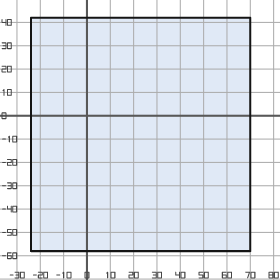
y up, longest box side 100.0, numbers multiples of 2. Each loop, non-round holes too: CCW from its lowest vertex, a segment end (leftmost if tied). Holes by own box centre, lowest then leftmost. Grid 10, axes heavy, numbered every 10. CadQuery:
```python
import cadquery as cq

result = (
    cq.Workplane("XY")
    .moveTo(-24.0, -58.0)
    .lineTo(70.0, -58.0)
    .lineTo(70.0, 42.0)
    .lineTo(-24.0, 42.0)
    .close()
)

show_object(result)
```